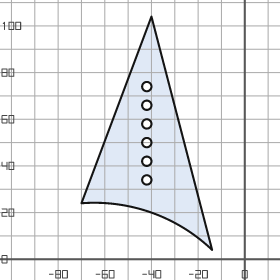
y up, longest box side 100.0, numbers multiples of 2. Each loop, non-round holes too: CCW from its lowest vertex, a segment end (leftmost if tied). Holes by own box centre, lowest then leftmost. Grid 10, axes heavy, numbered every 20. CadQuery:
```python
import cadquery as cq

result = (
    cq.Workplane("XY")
    .moveTo(-14.0, 4.0)
    .lineTo(-40.0, 104.0)
    .lineTo(-70.0, 24.0)
    .threePointArc((-40.0, 20.0), (-14.0, 4.0))
    .close()
    .moveTo(-42.0, 34.0)
    .circle(2.0)
    .moveTo(-42.0, 42.0)
    .circle(2.0)
    .moveTo(-42.0, 50.0)
    .circle(2.0)
    .moveTo(-42.0, 58.0)
    .circle(2.0)
    .moveTo(-42.0, 66.0)
    .circle(2.0)
    .moveTo(-42.0, 74.0)
    .circle(2.0)
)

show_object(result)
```